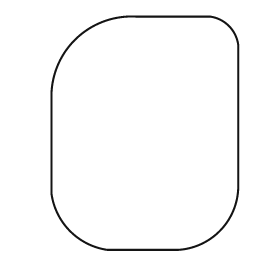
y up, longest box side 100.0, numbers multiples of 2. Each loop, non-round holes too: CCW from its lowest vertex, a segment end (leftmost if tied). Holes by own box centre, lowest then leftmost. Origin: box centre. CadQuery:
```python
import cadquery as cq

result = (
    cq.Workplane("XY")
    .moveTo(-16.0, -50.0)
    .lineTo(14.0, -50.0)
    .threePointArc((32.0, -42.0), (40.0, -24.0))
    .lineTo(40.0, 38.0)
    .threePointArc((36.0, 46.0), (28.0, 50.0))
    .lineTo(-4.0, 50.0)
    .threePointArc((-30.0, 40.0), (-40.0, 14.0))
    .lineTo(-40.0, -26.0)
    .threePointArc((-32.0, -42.0), (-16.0, -50.0))
    .close()
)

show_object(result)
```